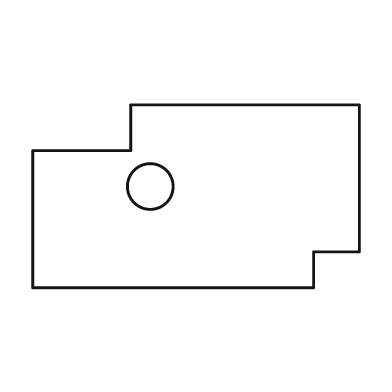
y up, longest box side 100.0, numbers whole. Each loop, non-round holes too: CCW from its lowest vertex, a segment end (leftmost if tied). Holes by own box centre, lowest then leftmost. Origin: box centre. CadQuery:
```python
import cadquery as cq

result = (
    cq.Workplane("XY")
    .moveTo(-50.0, -28.0)
    .lineTo(36.0, -28.0)
    .lineTo(36.0, -17.0)
    .lineTo(50.0, -17.0)
    .lineTo(50.0, 28.0)
    .lineTo(-20.0, 28.0)
    .lineTo(-20.0, 14.0)
    .lineTo(-50.0, 14.0)
    .close()
    .moveTo(-14.0, 3.0)
    .circle(7.0)
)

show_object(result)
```